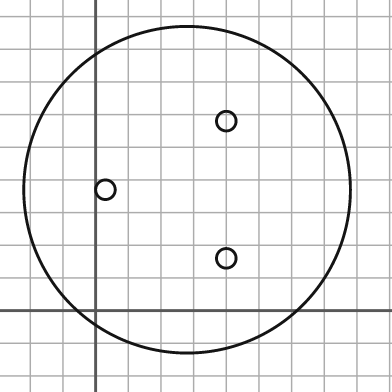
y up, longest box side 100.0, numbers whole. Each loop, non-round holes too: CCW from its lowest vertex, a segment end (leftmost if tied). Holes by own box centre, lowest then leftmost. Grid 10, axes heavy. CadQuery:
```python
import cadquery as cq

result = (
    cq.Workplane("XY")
    .moveTo(28.0, 37.0)
    .circle(50.0)
    .moveTo(40.0, 16.0)
    .circle(3.0)
    .moveTo(3.0, 37.0)
    .circle(3.0)
    .moveTo(40.0, 58.0)
    .circle(3.0)
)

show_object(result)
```